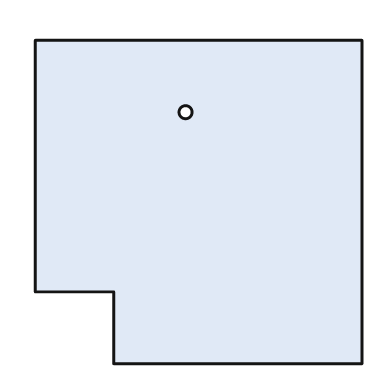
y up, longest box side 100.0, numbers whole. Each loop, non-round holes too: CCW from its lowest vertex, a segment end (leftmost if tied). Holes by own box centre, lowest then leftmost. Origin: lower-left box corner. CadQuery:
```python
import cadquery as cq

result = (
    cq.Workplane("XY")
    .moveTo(24.0, 0.0)
    .lineTo(100.0, 0.0)
    .lineTo(100.0, 99.0)
    .lineTo(0.0, 99.0)
    .lineTo(0.0, 22.0)
    .lineTo(24.0, 22.0)
    .close()
    .moveTo(46.0, 77.0)
    .circle(2.0)
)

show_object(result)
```